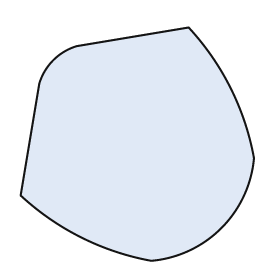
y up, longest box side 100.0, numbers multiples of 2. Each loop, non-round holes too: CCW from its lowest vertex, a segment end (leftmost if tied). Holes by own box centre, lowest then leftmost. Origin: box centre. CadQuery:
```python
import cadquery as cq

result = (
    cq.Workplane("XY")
    .moveTo(6.0, -50.0)
    .threePointArc((36.0, -36.0), (50.0, -6.0))
    .threePointArc((40.0, 24.0), (22.0, 50.0))
    .lineTo(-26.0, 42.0)
    .threePointArc((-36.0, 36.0), (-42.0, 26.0))
    .lineTo(-50.0, -22.0)
    .threePointArc((-24.0, -40.0), (6.0, -50.0))
    .close()
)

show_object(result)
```